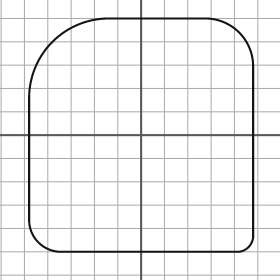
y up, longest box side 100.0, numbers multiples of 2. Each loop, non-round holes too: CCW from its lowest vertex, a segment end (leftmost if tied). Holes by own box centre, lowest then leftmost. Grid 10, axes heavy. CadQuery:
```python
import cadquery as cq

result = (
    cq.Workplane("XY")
    .moveTo(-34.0, -50.0)
    .lineTo(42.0, -50.0)
    .threePointArc((46.0, -48.0), (48.0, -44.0))
    .lineTo(48.0, 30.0)
    .threePointArc((42.0, 44.0), (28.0, 50.0))
    .lineTo(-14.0, 50.0)
    .threePointArc((-38.0, 40.0), (-48.0, 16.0))
    .lineTo(-48.0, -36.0)
    .threePointArc((-44.0, -46.0), (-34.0, -50.0))
    .close()
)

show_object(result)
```